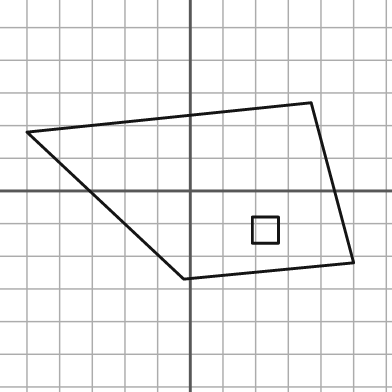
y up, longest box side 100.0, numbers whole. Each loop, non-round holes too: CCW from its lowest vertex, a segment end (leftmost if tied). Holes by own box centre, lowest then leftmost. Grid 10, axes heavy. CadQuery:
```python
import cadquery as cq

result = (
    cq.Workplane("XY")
    .moveTo(-2.0, -27.0)
    .lineTo(50.0, -22.0)
    .lineTo(37.0, 27.0)
    .lineTo(-50.0, 18.0)
    .close()
    .moveTo(19.0, -16.0)
    .lineTo(27.0, -16.0)
    .lineTo(27.0, -8.0)
    .lineTo(19.0, -8.0)
    .close()
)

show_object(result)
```